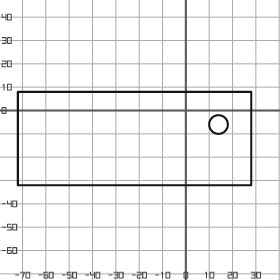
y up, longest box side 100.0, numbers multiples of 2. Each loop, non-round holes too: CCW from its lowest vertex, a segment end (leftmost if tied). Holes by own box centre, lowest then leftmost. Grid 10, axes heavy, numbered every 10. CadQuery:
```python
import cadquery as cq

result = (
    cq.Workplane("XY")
    .moveTo(-72.0, -32.0)
    .lineTo(28.0, -32.0)
    .lineTo(28.0, 8.0)
    .lineTo(-72.0, 8.0)
    .close()
    .moveTo(14.0, -6.0)
    .circle(4.0)
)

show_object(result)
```